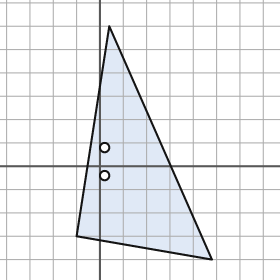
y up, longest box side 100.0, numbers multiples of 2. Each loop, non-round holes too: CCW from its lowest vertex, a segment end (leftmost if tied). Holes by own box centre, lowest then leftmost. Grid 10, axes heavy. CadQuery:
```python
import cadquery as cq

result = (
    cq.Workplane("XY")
    .moveTo(48.0, -40.0)
    .lineTo(4.0, 60.0)
    .lineTo(-10.0, -30.0)
    .close()
    .moveTo(2.0, -4.0)
    .circle(2.0)
    .moveTo(2.0, 8.0)
    .circle(2.0)
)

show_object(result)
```